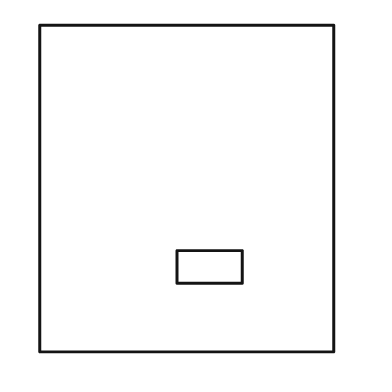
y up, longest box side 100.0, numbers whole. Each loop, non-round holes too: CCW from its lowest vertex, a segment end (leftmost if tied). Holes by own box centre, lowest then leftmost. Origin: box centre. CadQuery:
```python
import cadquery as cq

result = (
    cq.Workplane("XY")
    .moveTo(-45.0, -50.0)
    .lineTo(45.0, -50.0)
    .lineTo(45.0, 50.0)
    .lineTo(-45.0, 50.0)
    .close()
    .moveTo(-3.0, -29.0)
    .lineTo(17.0, -29.0)
    .lineTo(17.0, -19.0)
    .lineTo(-3.0, -19.0)
    .close()
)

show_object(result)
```